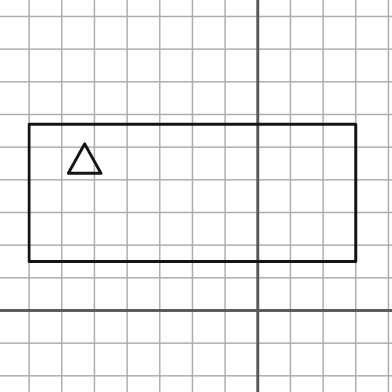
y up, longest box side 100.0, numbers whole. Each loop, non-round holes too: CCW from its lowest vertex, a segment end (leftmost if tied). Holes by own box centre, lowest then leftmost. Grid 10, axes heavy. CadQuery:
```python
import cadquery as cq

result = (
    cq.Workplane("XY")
    .moveTo(-70.0, 15.0)
    .lineTo(30.0, 15.0)
    .lineTo(30.0, 57.0)
    .lineTo(-70.0, 57.0)
    .close()
    .moveTo(-58.0, 42.0)
    .lineTo(-48.0, 42.0)
    .lineTo(-53.0, 51.0)
    .close()
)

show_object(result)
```